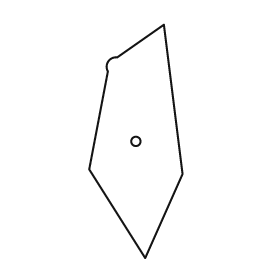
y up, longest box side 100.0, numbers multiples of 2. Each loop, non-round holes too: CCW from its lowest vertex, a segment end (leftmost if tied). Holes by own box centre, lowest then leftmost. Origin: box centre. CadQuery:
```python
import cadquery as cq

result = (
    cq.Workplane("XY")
    .moveTo(4.0, -50.0)
    .lineTo(20.0, -14.0)
    .lineTo(12.0, 50.0)
    .lineTo(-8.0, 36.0)
    .threePointArc((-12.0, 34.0), (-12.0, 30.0))
    .lineTo(-20.0, -12.0)
    .close()
    .moveTo(0.0, 0.0)
    .circle(2.0)
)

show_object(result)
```